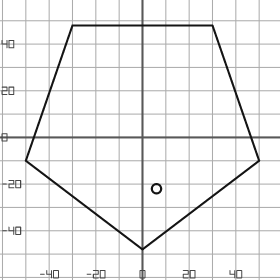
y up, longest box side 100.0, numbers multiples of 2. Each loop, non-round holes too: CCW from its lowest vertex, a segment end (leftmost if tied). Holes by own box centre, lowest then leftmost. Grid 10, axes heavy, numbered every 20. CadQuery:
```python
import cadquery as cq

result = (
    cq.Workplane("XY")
    .moveTo(0.0, -48.0)
    .lineTo(50.0, -10.0)
    .lineTo(30.0, 48.0)
    .lineTo(-30.0, 48.0)
    .lineTo(-50.0, -10.0)
    .close()
    .moveTo(6.0, -22.0)
    .circle(2.0)
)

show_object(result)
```